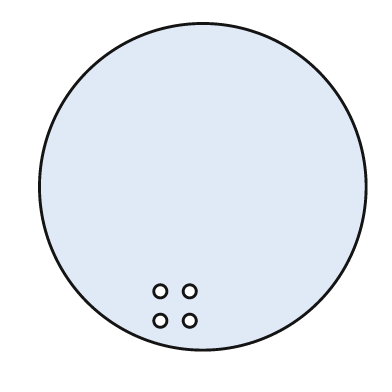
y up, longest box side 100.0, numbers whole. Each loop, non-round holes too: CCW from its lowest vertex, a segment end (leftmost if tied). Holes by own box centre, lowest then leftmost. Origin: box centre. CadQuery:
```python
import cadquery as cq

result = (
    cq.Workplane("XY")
    .moveTo(0.0, 0.0)
    .circle(50.0)
    .moveTo(-13.0, -41.0)
    .circle(2.0)
    .moveTo(-4.0, -41.0)
    .circle(2.0)
    .moveTo(-13.0, -32.0)
    .circle(2.0)
    .moveTo(-4.0, -32.0)
    .circle(2.0)
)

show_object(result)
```